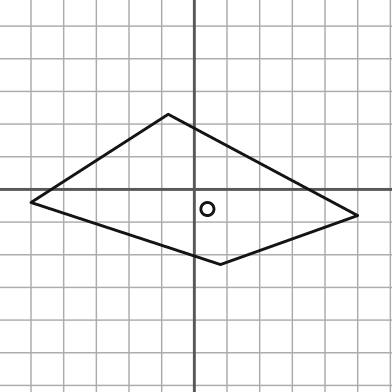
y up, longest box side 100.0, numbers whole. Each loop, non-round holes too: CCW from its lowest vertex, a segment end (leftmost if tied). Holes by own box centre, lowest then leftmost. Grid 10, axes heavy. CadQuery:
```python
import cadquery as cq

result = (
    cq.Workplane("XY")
    .moveTo(8.0, -23.0)
    .lineTo(50.0, -8.0)
    .lineTo(-8.0, 23.0)
    .lineTo(-50.0, -4.0)
    .close()
    .moveTo(4.0, -6.0)
    .circle(2.0)
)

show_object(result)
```